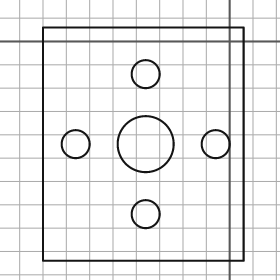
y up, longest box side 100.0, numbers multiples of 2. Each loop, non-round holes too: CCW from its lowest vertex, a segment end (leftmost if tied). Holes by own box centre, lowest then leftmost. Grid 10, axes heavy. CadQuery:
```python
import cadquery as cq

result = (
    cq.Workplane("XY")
    .moveTo(-80.0, -94.0)
    .lineTo(6.0, -94.0)
    .lineTo(6.0, 6.0)
    .lineTo(-80.0, 6.0)
    .close()
    .moveTo(-36.0, -74.0)
    .circle(6.0)
    .moveTo(-66.0, -44.0)
    .circle(6.0)
    .moveTo(-36.0, -44.0)
    .circle(12.0)
    .moveTo(-6.0, -44.0)
    .circle(6.0)
    .moveTo(-36.0, -14.0)
    .circle(6.0)
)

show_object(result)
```